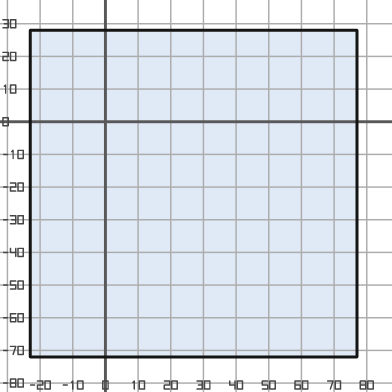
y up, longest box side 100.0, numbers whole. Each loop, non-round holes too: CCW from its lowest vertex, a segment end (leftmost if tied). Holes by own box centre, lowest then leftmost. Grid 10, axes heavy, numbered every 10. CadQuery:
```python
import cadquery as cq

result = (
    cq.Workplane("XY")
    .moveTo(-23.0, -72.0)
    .lineTo(77.0, -72.0)
    .lineTo(77.0, 28.0)
    .lineTo(-23.0, 28.0)
    .close()
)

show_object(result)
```